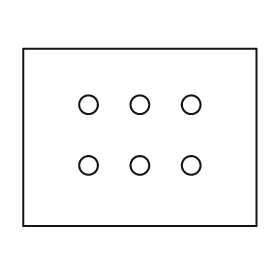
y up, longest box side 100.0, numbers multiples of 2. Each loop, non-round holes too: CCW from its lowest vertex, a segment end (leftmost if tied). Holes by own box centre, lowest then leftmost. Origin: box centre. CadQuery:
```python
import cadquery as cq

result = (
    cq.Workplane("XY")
    .moveTo(-50.0, -38.0)
    .lineTo(50.0, -38.0)
    .lineTo(50.0, 38.0)
    .lineTo(-50.0, 38.0)
    .close()
    .moveTo(-22.0, -12.0)
    .circle(4.0)
    .moveTo(0.0, -12.0)
    .circle(4.0)
    .moveTo(22.0, -12.0)
    .circle(4.0)
    .moveTo(-22.0, 14.0)
    .circle(4.0)
    .moveTo(0.0, 14.0)
    .circle(4.0)
    .moveTo(22.0, 14.0)
    .circle(4.0)
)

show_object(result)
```